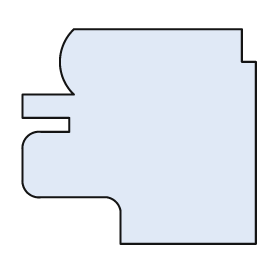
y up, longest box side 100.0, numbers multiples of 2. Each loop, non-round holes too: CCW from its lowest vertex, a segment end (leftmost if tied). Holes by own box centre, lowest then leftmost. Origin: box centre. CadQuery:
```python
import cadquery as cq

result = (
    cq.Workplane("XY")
    .moveTo(-8.0, -46.0)
    .lineTo(50.0, -46.0)
    .lineTo(50.0, 32.0)
    .lineTo(44.0, 32.0)
    .lineTo(44.0, 46.0)
    .lineTo(-28.0, 46.0)
    .threePointArc((-34.0, 32.0), (-28.0, 18.0))
    .lineTo(-50.0, 18.0)
    .lineTo(-50.0, 8.0)
    .lineTo(-30.0, 8.0)
    .lineTo(-30.0, 2.0)
    .lineTo(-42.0, 2.0)
    .threePointArc((-48.0, 0.0), (-50.0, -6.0))
    .lineTo(-50.0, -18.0)
    .threePointArc((-48.0, -24.0), (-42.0, -26.0))
    .lineTo(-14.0, -26.0)
    .threePointArc((-10.0, -28.0), (-8.0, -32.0))
    .close()
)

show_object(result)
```